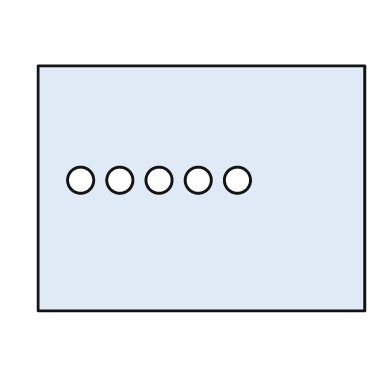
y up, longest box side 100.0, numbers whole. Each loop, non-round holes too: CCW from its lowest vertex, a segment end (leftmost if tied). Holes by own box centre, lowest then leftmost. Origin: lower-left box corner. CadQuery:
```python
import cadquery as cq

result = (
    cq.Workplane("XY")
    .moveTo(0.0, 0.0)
    .lineTo(100.0, 0.0)
    .lineTo(100.0, 75.0)
    .lineTo(0.0, 75.0)
    .close()
    .moveTo(13.0, 40.0)
    .circle(4.0)
    .moveTo(25.0, 40.0)
    .circle(4.0)
    .moveTo(37.0, 40.0)
    .circle(4.0)
    .moveTo(49.0, 40.0)
    .circle(4.0)
    .moveTo(61.0, 40.0)
    .circle(4.0)
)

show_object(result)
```